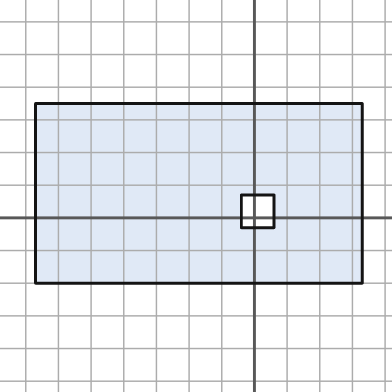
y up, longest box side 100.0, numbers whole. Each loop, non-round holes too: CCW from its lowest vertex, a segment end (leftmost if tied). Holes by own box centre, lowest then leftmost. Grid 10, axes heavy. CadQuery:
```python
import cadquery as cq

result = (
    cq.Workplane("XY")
    .moveTo(-67.0, -20.0)
    .lineTo(33.0, -20.0)
    .lineTo(33.0, 35.0)
    .lineTo(-67.0, 35.0)
    .close()
    .moveTo(-4.0, -3.0)
    .lineTo(6.0, -3.0)
    .lineTo(6.0, 7.0)
    .lineTo(-4.0, 7.0)
    .close()
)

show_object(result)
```